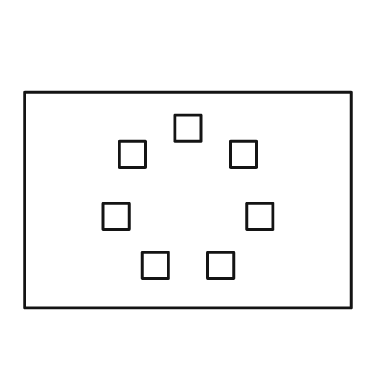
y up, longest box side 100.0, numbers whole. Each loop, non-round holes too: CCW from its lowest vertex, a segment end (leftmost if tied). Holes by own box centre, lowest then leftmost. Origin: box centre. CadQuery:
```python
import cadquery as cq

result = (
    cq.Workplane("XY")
    .moveTo(-50.0, -33.0)
    .lineTo(50.0, -33.0)
    .lineTo(50.0, 33.0)
    .lineTo(-50.0, 33.0)
    .close()
    .moveTo(-14.0, -24.0)
    .lineTo(-6.0, -24.0)
    .lineTo(-6.0, -16.0)
    .lineTo(-14.0, -16.0)
    .close()
    .moveTo(6.0, -24.0)
    .lineTo(14.0, -24.0)
    .lineTo(14.0, -16.0)
    .lineTo(6.0, -16.0)
    .close()
    .moveTo(-26.0, -9.0)
    .lineTo(-18.0, -9.0)
    .lineTo(-18.0, -1.0)
    .lineTo(-26.0, -1.0)
    .close()
    .moveTo(18.0, -9.0)
    .lineTo(26.0, -9.0)
    .lineTo(26.0, -1.0)
    .lineTo(18.0, -1.0)
    .close()
    .moveTo(-21.0, 10.0)
    .lineTo(-13.0, 10.0)
    .lineTo(-13.0, 18.0)
    .lineTo(-21.0, 18.0)
    .close()
    .moveTo(13.0, 10.0)
    .lineTo(21.0, 10.0)
    .lineTo(21.0, 18.0)
    .lineTo(13.0, 18.0)
    .close()
    .moveTo(-4.0, 18.0)
    .lineTo(4.0, 18.0)
    .lineTo(4.0, 26.0)
    .lineTo(-4.0, 26.0)
    .close()
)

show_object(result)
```